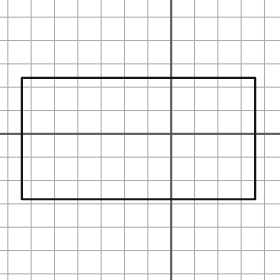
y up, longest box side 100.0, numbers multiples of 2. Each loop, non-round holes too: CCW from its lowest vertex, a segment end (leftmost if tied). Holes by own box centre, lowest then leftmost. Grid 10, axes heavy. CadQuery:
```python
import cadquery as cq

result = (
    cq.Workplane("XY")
    .moveTo(-64.0, -28.0)
    .lineTo(36.0, -28.0)
    .lineTo(36.0, 24.0)
    .lineTo(-64.0, 24.0)
    .close()
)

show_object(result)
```